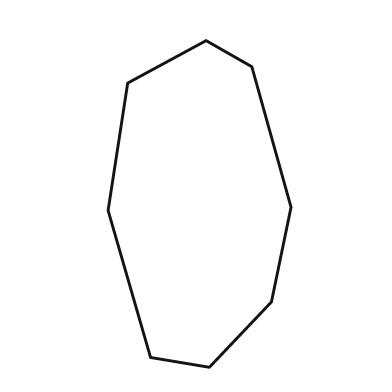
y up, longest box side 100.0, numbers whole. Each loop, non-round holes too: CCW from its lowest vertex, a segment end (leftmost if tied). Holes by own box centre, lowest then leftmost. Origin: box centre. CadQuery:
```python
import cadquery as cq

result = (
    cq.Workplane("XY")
    .moveTo(3.0, -50.0)
    .lineTo(22.0, -30.0)
    .lineTo(28.0, -1.0)
    .lineTo(16.0, 42.0)
    .lineTo(2.0, 50.0)
    .lineTo(-22.0, 37.0)
    .lineTo(-28.0, -2.0)
    .lineTo(-15.0, -47.0)
    .close()
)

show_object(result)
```